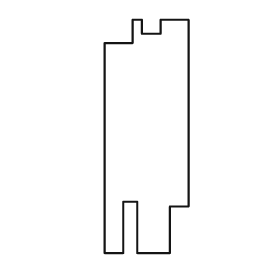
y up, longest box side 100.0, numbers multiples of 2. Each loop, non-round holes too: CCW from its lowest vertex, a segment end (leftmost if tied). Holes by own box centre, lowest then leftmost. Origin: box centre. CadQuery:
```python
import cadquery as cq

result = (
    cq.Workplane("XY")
    .moveTo(-18.0, -50.0)
    .lineTo(-10.0, -50.0)
    .lineTo(-10.0, -28.0)
    .lineTo(-4.0, -28.0)
    .lineTo(-4.0, -50.0)
    .lineTo(10.0, -50.0)
    .lineTo(10.0, -30.0)
    .lineTo(18.0, -30.0)
    .lineTo(18.0, 50.0)
    .lineTo(6.0, 50.0)
    .lineTo(6.0, 44.0)
    .lineTo(-2.0, 44.0)
    .lineTo(-2.0, 50.0)
    .lineTo(-6.0, 50.0)
    .lineTo(-6.0, 40.0)
    .lineTo(-18.0, 40.0)
    .close()
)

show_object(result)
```